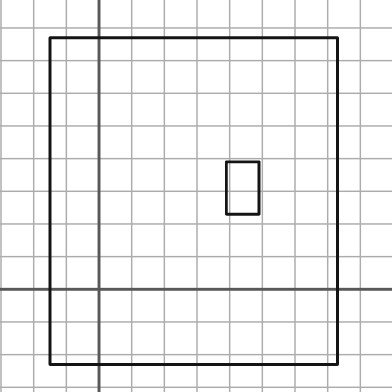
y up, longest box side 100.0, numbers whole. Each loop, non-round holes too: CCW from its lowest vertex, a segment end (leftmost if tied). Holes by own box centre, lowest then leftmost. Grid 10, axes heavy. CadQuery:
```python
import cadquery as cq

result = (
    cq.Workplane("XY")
    .moveTo(-15.0, -23.0)
    .lineTo(73.0, -23.0)
    .lineTo(73.0, 77.0)
    .lineTo(-15.0, 77.0)
    .close()
    .moveTo(39.0, 23.0)
    .lineTo(49.0, 23.0)
    .lineTo(49.0, 39.0)
    .lineTo(39.0, 39.0)
    .close()
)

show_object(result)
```